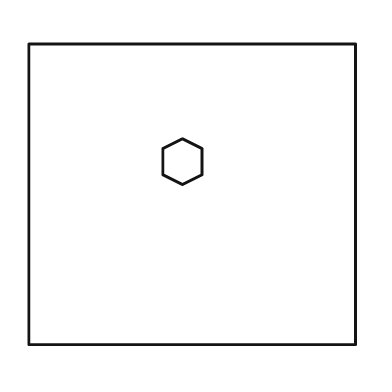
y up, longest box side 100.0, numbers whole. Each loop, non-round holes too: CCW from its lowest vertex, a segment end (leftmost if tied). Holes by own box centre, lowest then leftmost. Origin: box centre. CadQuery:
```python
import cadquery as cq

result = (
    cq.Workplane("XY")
    .moveTo(-50.0, -46.0)
    .lineTo(50.0, -46.0)
    .lineTo(50.0, 46.0)
    .lineTo(-50.0, 46.0)
    .close()
    .moveTo(-3.0, 3.0)
    .lineTo(3.0, 6.0)
    .lineTo(3.0, 14.0)
    .lineTo(-3.0, 17.0)
    .lineTo(-9.0, 14.0)
    .lineTo(-9.0, 6.0)
    .close()
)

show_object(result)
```